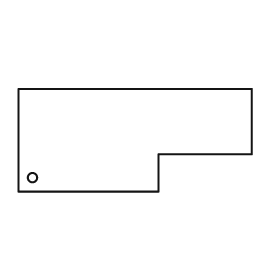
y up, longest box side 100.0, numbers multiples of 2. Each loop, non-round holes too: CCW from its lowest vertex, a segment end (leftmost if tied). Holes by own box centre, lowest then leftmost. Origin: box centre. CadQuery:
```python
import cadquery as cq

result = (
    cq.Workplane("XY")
    .moveTo(-50.0, -22.0)
    .lineTo(10.0, -22.0)
    .lineTo(10.0, -6.0)
    .lineTo(50.0, -6.0)
    .lineTo(50.0, 22.0)
    .lineTo(-50.0, 22.0)
    .close()
    .moveTo(-44.0, -16.0)
    .circle(2.0)
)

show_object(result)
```